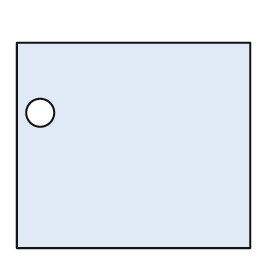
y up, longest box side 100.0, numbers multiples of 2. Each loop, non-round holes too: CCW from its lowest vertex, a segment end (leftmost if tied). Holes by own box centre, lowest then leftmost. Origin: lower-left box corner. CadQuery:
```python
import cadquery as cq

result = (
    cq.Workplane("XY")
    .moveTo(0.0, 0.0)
    .lineTo(100.0, 0.0)
    .lineTo(100.0, 88.0)
    .lineTo(0.0, 88.0)
    .close()
    .moveTo(10.0, 58.0)
    .circle(6.0)
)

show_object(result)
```